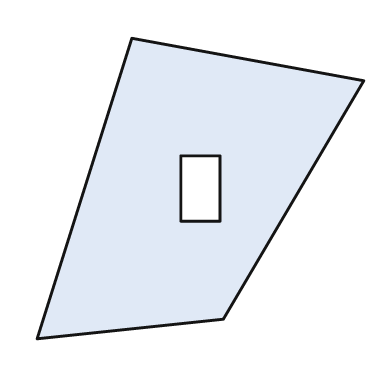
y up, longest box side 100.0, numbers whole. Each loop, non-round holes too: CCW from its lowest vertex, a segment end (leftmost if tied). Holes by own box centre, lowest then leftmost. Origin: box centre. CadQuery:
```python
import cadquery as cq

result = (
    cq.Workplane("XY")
    .moveTo(-50.0, -46.0)
    .lineTo(7.0, -40.0)
    .lineTo(50.0, 33.0)
    .lineTo(-21.0, 46.0)
    .close()
    .moveTo(-6.0, -10.0)
    .lineTo(6.0, -10.0)
    .lineTo(6.0, 10.0)
    .lineTo(-6.0, 10.0)
    .close()
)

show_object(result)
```